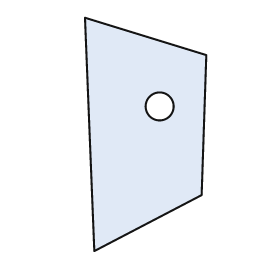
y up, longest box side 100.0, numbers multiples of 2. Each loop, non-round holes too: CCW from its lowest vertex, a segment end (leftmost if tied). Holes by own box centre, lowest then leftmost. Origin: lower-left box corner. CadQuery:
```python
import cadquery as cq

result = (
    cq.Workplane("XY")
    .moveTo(4.0, 0.0)
    .lineTo(50.0, 24.0)
    .lineTo(52.0, 84.0)
    .lineTo(0.0, 100.0)
    .close()
    .moveTo(32.0, 62.0)
    .circle(6.0)
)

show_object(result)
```